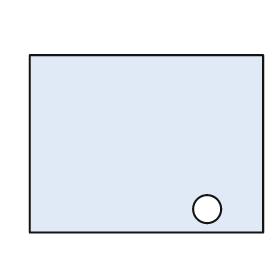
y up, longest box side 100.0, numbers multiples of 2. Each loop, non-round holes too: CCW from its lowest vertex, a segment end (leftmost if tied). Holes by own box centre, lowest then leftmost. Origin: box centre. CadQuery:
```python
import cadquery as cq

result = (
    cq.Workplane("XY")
    .moveTo(-50.0, -38.0)
    .lineTo(50.0, -38.0)
    .lineTo(50.0, 38.0)
    .lineTo(-50.0, 38.0)
    .close()
    .moveTo(26.0, -28.0)
    .circle(6.0)
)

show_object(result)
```